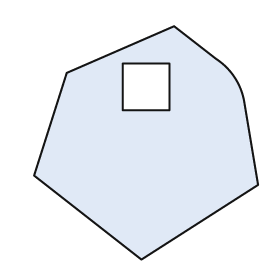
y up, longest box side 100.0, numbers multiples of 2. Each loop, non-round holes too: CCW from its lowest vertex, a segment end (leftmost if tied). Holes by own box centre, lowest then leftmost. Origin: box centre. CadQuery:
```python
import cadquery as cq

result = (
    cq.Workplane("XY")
    .moveTo(-2.0, -50.0)
    .lineTo(48.0, -18.0)
    .lineTo(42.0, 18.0)
    .threePointArc((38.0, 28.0), (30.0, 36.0))
    .lineTo(12.0, 50.0)
    .lineTo(-34.0, 30.0)
    .lineTo(-48.0, -14.0)
    .close()
    .moveTo(-10.0, 14.0)
    .lineTo(10.0, 14.0)
    .lineTo(10.0, 34.0)
    .lineTo(-10.0, 34.0)
    .close()
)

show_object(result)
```